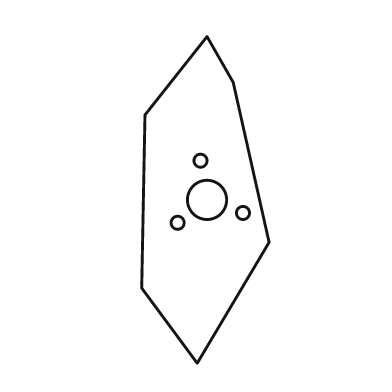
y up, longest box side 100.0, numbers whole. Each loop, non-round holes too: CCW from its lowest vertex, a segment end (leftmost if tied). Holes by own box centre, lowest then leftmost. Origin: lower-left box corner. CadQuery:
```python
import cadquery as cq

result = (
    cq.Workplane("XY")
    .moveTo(17.0, 0.0)
    .lineTo(39.0, 37.0)
    .lineTo(28.0, 86.0)
    .lineTo(20.0, 100.0)
    .lineTo(1.0, 76.0)
    .lineTo(0.0, 23.0)
    .close()
    .moveTo(11.0, 43.0)
    .circle(2.0)
    .moveTo(31.0, 46.0)
    .circle(2.0)
    .moveTo(20.0, 50.0)
    .circle(6.0)
    .moveTo(18.0, 62.0)
    .circle(2.0)
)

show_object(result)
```